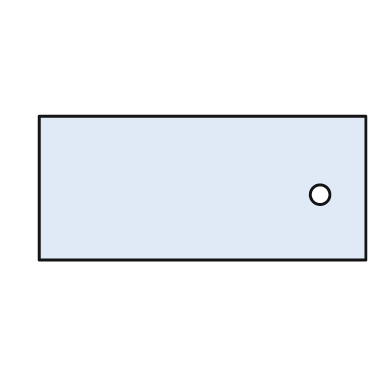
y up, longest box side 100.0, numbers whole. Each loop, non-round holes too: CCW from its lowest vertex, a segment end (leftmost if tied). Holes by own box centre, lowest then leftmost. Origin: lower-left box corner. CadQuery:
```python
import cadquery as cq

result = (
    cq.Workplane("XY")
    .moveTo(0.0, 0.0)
    .lineTo(100.0, 0.0)
    .lineTo(100.0, 44.0)
    .lineTo(0.0, 44.0)
    .close()
    .moveTo(86.0, 20.0)
    .circle(3.0)
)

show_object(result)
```